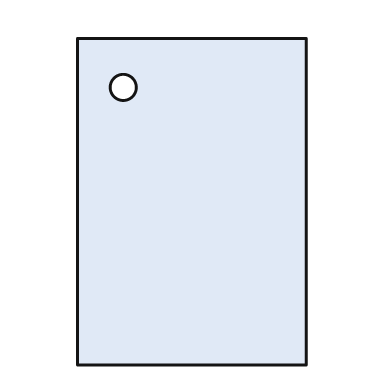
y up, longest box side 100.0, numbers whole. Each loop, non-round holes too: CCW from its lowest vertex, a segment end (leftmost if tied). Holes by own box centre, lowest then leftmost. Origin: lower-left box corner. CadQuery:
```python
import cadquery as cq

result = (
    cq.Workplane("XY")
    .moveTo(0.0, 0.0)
    .lineTo(70.0, 0.0)
    .lineTo(70.0, 100.0)
    .lineTo(0.0, 100.0)
    .close()
    .moveTo(14.0, 85.0)
    .circle(4.0)
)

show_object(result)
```